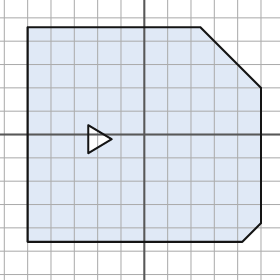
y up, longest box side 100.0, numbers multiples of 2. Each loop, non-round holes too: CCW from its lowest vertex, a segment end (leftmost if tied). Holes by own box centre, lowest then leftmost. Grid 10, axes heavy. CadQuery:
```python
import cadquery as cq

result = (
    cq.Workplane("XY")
    .moveTo(-50.0, -46.0)
    .lineTo(42.0, -46.0)
    .lineTo(50.0, -38.0)
    .lineTo(50.0, 20.0)
    .lineTo(24.0, 46.0)
    .lineTo(-50.0, 46.0)
    .close()
    .moveTo(-24.0, -8.0)
    .lineTo(-14.0, -2.0)
    .lineTo(-24.0, 4.0)
    .close()
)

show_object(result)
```